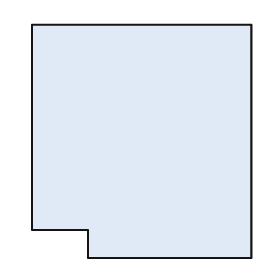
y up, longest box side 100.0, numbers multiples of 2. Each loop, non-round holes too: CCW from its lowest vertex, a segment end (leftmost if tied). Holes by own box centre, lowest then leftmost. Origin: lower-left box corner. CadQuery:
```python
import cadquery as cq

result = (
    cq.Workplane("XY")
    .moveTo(24.0, 0.0)
    .lineTo(94.0, 0.0)
    .lineTo(94.0, 100.0)
    .lineTo(0.0, 100.0)
    .lineTo(0.0, 12.0)
    .lineTo(24.0, 12.0)
    .close()
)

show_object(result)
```